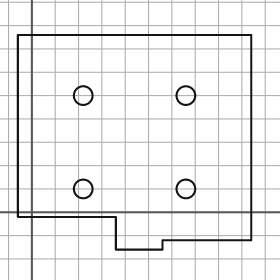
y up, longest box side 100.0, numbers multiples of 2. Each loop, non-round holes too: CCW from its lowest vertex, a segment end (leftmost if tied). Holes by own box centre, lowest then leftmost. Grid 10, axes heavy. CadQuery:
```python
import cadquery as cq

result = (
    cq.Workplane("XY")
    .moveTo(36.0, -16.0)
    .lineTo(56.0, -16.0)
    .lineTo(56.0, -12.0)
    .lineTo(94.0, -12.0)
    .lineTo(94.0, 76.0)
    .lineTo(-6.0, 76.0)
    .lineTo(-6.0, -2.0)
    .lineTo(36.0, -2.0)
    .close()
    .moveTo(22.0, 10.0)
    .circle(4.0)
    .moveTo(66.0, 10.0)
    .circle(4.0)
    .moveTo(22.0, 50.0)
    .circle(4.0)
    .moveTo(66.0, 50.0)
    .circle(4.0)
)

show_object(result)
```